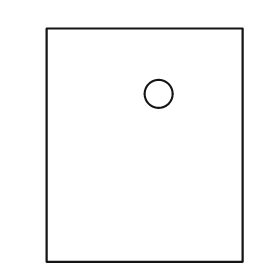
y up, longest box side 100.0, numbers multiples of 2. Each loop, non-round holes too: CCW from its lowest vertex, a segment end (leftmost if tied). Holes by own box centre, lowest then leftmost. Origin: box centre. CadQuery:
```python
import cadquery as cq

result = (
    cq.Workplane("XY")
    .moveTo(-42.0, -50.0)
    .lineTo(42.0, -50.0)
    .lineTo(42.0, 50.0)
    .lineTo(-42.0, 50.0)
    .close()
    .moveTo(6.0, 22.0)
    .circle(6.0)
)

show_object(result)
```